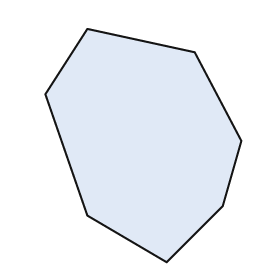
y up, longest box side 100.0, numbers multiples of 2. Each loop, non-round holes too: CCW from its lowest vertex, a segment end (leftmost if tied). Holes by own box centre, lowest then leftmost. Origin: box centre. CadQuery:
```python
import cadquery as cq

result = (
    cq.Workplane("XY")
    .moveTo(10.0, -50.0)
    .lineTo(34.0, -26.0)
    .lineTo(42.0, 2.0)
    .lineTo(22.0, 40.0)
    .lineTo(-24.0, 50.0)
    .lineTo(-42.0, 22.0)
    .lineTo(-24.0, -30.0)
    .close()
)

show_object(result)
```